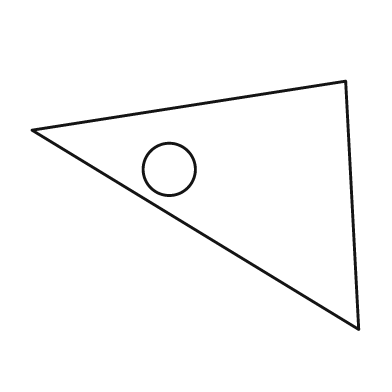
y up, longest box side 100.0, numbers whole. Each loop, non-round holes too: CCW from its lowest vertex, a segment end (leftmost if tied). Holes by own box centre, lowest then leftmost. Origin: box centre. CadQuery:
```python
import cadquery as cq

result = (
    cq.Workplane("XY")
    .moveTo(50.0, -38.0)
    .lineTo(46.0, 38.0)
    .lineTo(-50.0, 23.0)
    .close()
    .moveTo(-8.0, 11.0)
    .circle(8.0)
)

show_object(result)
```